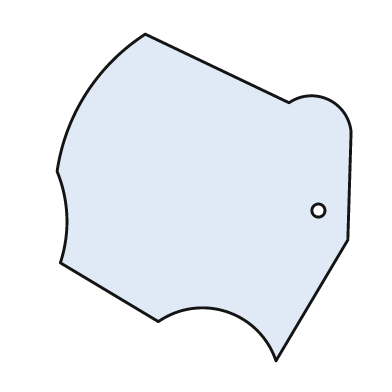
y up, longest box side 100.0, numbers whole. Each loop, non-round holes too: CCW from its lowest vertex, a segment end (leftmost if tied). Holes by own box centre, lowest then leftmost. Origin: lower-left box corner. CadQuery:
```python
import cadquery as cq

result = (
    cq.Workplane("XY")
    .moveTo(67.0, 0.0)
    .lineTo(89.0, 37.0)
    .lineTo(90.0, 70.0)
    .threePointArc((83.0, 80.0), (71.0, 79.0))
    .lineTo(27.0, 100.0)
    .threePointArc((9.0, 82.0), (0.0, 58.0))
    .threePointArc((3.0, 44.0), (1.0, 30.0))
    .lineTo(31.0, 12.0)
    .threePointArc((52.0, 15.0), (67.0, 0.0))
    .close()
    .moveTo(80.0, 46.0)
    .circle(2.0)
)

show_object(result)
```